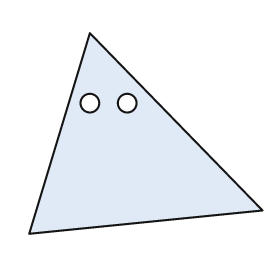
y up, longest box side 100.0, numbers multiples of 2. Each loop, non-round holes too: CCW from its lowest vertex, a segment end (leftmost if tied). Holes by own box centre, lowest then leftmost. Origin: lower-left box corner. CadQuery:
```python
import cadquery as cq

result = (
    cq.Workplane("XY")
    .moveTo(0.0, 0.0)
    .lineTo(100.0, 10.0)
    .lineTo(26.0, 86.0)
    .close()
    .moveTo(26.0, 56.0)
    .circle(4.0)
    .moveTo(42.0, 56.0)
    .circle(4.0)
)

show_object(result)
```